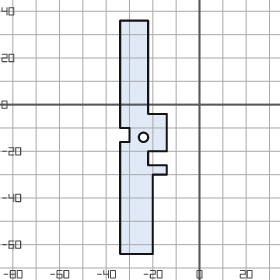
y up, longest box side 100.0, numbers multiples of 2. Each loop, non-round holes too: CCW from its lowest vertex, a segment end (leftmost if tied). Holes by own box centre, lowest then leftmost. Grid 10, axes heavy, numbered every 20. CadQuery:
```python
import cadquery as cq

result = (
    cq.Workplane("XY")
    .moveTo(-34.0, -64.0)
    .lineTo(-20.0, -64.0)
    .lineTo(-20.0, -30.0)
    .lineTo(-14.0, -30.0)
    .lineTo(-14.0, -26.0)
    .lineTo(-22.0, -26.0)
    .lineTo(-22.0, -20.0)
    .lineTo(-14.0, -20.0)
    .lineTo(-14.0, -4.0)
    .lineTo(-22.0, -4.0)
    .lineTo(-22.0, 36.0)
    .lineTo(-34.0, 36.0)
    .lineTo(-34.0, -10.0)
    .lineTo(-30.0, -10.0)
    .lineTo(-30.0, -16.0)
    .lineTo(-34.0, -16.0)
    .close()
    .moveTo(-24.0, -14.0)
    .circle(2.0)
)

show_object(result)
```